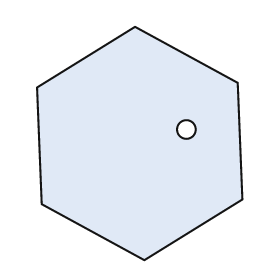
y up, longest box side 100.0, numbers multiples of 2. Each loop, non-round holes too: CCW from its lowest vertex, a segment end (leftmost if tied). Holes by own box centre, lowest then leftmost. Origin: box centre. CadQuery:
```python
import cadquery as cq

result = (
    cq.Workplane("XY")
    .moveTo(2.0, -50.0)
    .lineTo(44.0, -24.0)
    .lineTo(42.0, 26.0)
    .lineTo(-2.0, 50.0)
    .lineTo(-44.0, 24.0)
    .lineTo(-42.0, -26.0)
    .close()
    .moveTo(20.0, 6.0)
    .circle(4.0)
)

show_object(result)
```